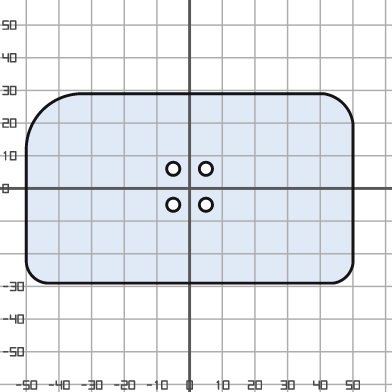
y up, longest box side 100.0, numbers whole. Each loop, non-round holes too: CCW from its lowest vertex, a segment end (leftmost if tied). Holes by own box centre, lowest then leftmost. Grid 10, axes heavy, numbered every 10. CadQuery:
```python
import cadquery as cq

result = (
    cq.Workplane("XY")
    .moveTo(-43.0, -29.0)
    .lineTo(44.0, -29.0)
    .threePointArc((48.0, -27.0), (50.0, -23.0))
    .lineTo(50.0, 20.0)
    .threePointArc((47.0, 26.0), (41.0, 29.0))
    .lineTo(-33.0, 29.0)
    .threePointArc((-45.0, 24.0), (-50.0, 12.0))
    .lineTo(-50.0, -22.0)
    .threePointArc((-48.0, -27.0), (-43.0, -29.0))
    .close()
    .moveTo(-5.0, -5.0)
    .circle(2.0)
    .moveTo(5.0, -5.0)
    .circle(2.0)
    .moveTo(-5.0, 6.0)
    .circle(2.0)
    .moveTo(5.0, 6.0)
    .circle(2.0)
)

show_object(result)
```